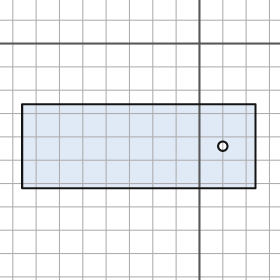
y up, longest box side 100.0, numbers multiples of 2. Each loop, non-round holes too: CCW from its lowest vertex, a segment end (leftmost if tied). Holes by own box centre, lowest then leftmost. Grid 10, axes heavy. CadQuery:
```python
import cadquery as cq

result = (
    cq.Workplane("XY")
    .moveTo(-76.0, -62.0)
    .lineTo(24.0, -62.0)
    .lineTo(24.0, -26.0)
    .lineTo(-76.0, -26.0)
    .close()
    .moveTo(10.0, -44.0)
    .circle(2.0)
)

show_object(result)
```